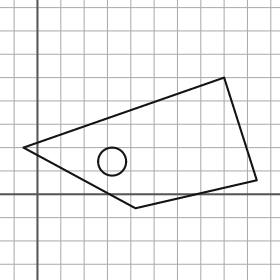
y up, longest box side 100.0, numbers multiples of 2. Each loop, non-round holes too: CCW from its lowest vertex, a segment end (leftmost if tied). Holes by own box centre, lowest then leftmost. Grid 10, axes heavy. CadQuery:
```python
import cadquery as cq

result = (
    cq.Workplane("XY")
    .moveTo(42.0, -6.0)
    .lineTo(94.0, 6.0)
    .lineTo(80.0, 50.0)
    .lineTo(-6.0, 20.0)
    .close()
    .moveTo(32.0, 14.0)
    .circle(6.0)
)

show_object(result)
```